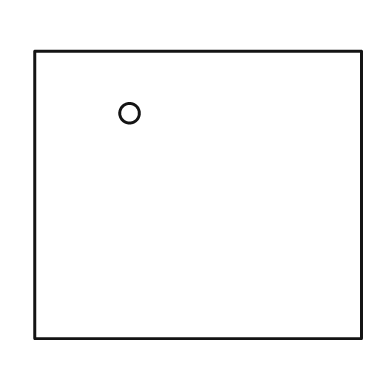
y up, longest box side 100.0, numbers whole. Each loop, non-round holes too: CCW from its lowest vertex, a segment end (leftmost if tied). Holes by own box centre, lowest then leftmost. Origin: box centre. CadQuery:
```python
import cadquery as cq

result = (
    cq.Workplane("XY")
    .moveTo(-50.0, -44.0)
    .lineTo(50.0, -44.0)
    .lineTo(50.0, 44.0)
    .lineTo(-50.0, 44.0)
    .close()
    .moveTo(-21.0, 25.0)
    .circle(3.0)
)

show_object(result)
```